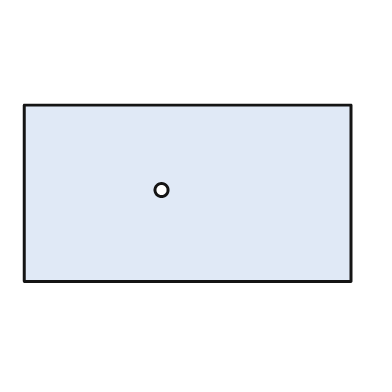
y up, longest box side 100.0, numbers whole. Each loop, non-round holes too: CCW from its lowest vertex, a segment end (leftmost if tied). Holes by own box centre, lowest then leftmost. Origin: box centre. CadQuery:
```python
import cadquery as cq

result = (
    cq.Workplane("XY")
    .moveTo(-50.0, -27.0)
    .lineTo(50.0, -27.0)
    .lineTo(50.0, 27.0)
    .lineTo(-50.0, 27.0)
    .close()
    .moveTo(-8.0, 1.0)
    .circle(2.0)
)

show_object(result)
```